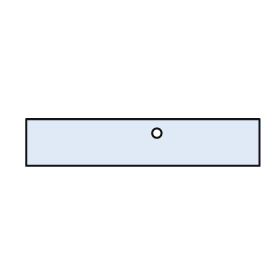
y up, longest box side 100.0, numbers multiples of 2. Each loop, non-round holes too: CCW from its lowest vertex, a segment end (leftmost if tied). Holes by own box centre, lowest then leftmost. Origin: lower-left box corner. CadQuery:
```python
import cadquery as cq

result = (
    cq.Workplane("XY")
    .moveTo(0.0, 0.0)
    .lineTo(100.0, 0.0)
    .lineTo(100.0, 20.0)
    .lineTo(0.0, 20.0)
    .close()
    .moveTo(56.0, 14.0)
    .circle(2.0)
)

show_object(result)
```